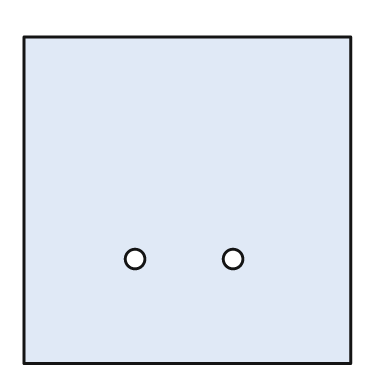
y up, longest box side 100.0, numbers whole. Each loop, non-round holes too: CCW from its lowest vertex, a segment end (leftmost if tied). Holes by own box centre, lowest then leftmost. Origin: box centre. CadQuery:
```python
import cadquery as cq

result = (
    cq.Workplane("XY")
    .moveTo(-50.0, -50.0)
    .lineTo(50.0, -50.0)
    .lineTo(50.0, 50.0)
    .lineTo(-50.0, 50.0)
    .close()
    .moveTo(-16.0, -18.0)
    .circle(3.0)
    .moveTo(14.0, -18.0)
    .circle(3.0)
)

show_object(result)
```